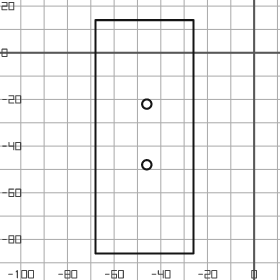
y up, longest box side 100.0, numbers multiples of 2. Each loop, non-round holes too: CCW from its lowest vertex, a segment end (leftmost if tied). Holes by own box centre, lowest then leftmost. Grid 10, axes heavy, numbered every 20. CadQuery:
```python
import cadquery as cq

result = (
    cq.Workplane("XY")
    .moveTo(-68.0, -86.0)
    .lineTo(-26.0, -86.0)
    .lineTo(-26.0, 14.0)
    .lineTo(-68.0, 14.0)
    .close()
    .moveTo(-46.0, -48.0)
    .circle(2.0)
    .moveTo(-46.0, -22.0)
    .circle(2.0)
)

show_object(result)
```